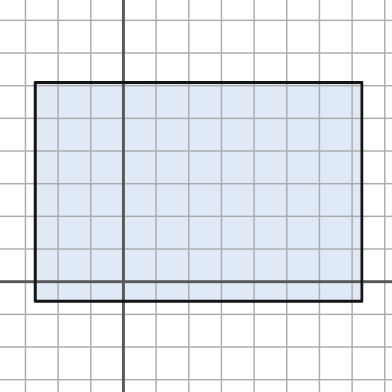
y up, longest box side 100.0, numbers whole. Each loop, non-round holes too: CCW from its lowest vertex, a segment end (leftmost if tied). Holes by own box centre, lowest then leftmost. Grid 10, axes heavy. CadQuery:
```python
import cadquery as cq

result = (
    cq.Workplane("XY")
    .moveTo(-27.0, -6.0)
    .lineTo(73.0, -6.0)
    .lineTo(73.0, 61.0)
    .lineTo(-27.0, 61.0)
    .close()
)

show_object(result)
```